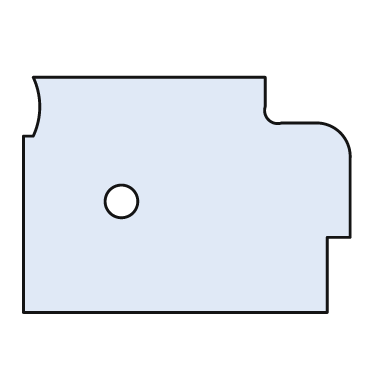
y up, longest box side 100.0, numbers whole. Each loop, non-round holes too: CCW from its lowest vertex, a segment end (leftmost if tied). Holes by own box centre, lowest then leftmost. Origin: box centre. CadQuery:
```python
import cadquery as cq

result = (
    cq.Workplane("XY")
    .moveTo(-50.0, -36.0)
    .lineTo(43.0, -36.0)
    .lineTo(43.0, -13.0)
    .lineTo(50.0, -13.0)
    .lineTo(50.0, 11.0)
    .threePointArc((47.0, 19.0), (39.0, 22.0))
    .lineTo(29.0, 22.0)
    .threePointArc((25.0, 23.0), (24.0, 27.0))
    .lineTo(24.0, 36.0)
    .lineTo(-47.0, 36.0)
    .threePointArc((-45.0, 27.0), (-47.0, 18.0))
    .lineTo(-50.0, 18.0)
    .close()
    .moveTo(-20.0, -2.0)
    .circle(5.0)
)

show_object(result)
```